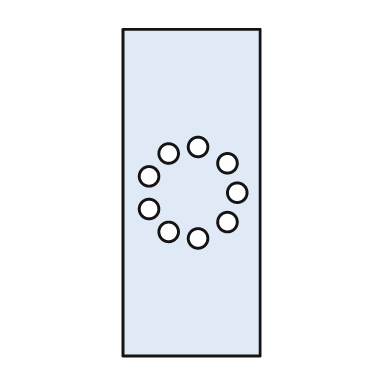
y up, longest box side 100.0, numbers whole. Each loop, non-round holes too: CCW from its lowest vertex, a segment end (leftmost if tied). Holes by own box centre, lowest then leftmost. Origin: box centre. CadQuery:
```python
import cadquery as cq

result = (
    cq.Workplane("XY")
    .moveTo(-21.0, -50.0)
    .lineTo(21.0, -50.0)
    .lineTo(21.0, 50.0)
    .lineTo(-21.0, 50.0)
    .close()
    .moveTo(2.0, -14.0)
    .circle(3.0)
    .moveTo(-7.0, -12.0)
    .circle(3.0)
    .moveTo(11.0, -9.0)
    .circle(3.0)
    .moveTo(-13.0, -5.0)
    .circle(3.0)
    .moveTo(14.0, 0.0)
    .circle(3.0)
    .moveTo(-13.0, 5.0)
    .circle(3.0)
    .moveTo(11.0, 9.0)
    .circle(3.0)
    .moveTo(-7.0, 12.0)
    .circle(3.0)
    .moveTo(2.0, 14.0)
    .circle(3.0)
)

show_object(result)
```